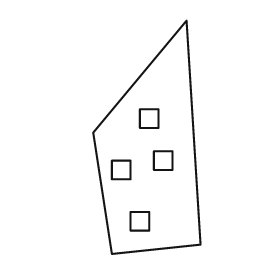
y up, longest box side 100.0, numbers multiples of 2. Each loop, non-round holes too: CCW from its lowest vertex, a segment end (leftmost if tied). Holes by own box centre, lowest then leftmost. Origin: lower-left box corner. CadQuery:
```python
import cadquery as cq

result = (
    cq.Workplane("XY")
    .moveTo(8.0, 0.0)
    .lineTo(46.0, 4.0)
    .lineTo(40.0, 100.0)
    .lineTo(0.0, 52.0)
    .close()
    .moveTo(16.0, 10.0)
    .lineTo(24.0, 10.0)
    .lineTo(24.0, 18.0)
    .lineTo(16.0, 18.0)
    .close()
    .moveTo(8.0, 32.0)
    .lineTo(16.0, 32.0)
    .lineTo(16.0, 40.0)
    .lineTo(8.0, 40.0)
    .close()
    .moveTo(26.0, 36.0)
    .lineTo(34.0, 36.0)
    .lineTo(34.0, 44.0)
    .lineTo(26.0, 44.0)
    .close()
    .moveTo(20.0, 54.0)
    .lineTo(28.0, 54.0)
    .lineTo(28.0, 62.0)
    .lineTo(20.0, 62.0)
    .close()
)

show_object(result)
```